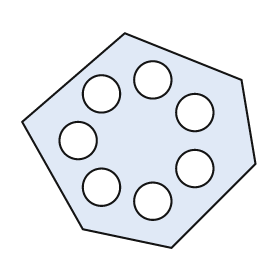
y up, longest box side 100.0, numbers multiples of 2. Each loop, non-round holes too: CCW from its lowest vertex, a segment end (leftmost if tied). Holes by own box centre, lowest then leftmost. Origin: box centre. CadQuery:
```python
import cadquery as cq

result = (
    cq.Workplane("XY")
    .moveTo(14.0, -46.0)
    .lineTo(50.0, -10.0)
    .lineTo(44.0, 26.0)
    .lineTo(-6.0, 46.0)
    .lineTo(-50.0, 8.0)
    .lineTo(-24.0, -38.0)
    .close()
    .moveTo(6.0, -26.0)
    .circle(8.0)
    .moveTo(-16.0, -20.0)
    .circle(8.0)
    .moveTo(24.0, -12.0)
    .circle(8.0)
    .moveTo(-26.0, 0.0)
    .circle(8.0)
    .moveTo(24.0, 12.0)
    .circle(8.0)
    .moveTo(-16.0, 20.0)
    .circle(8.0)
    .moveTo(6.0, 26.0)
    .circle(8.0)
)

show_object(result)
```